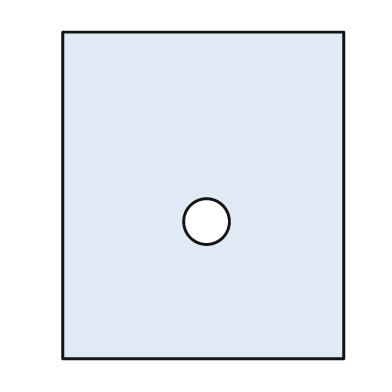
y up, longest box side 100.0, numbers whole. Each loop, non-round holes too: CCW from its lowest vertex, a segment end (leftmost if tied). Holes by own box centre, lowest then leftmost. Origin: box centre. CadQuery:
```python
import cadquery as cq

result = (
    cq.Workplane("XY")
    .moveTo(-43.0, -50.0)
    .lineTo(43.0, -50.0)
    .lineTo(43.0, 50.0)
    .lineTo(-43.0, 50.0)
    .close()
    .moveTo(1.0, -8.0)
    .circle(7.0)
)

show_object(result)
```